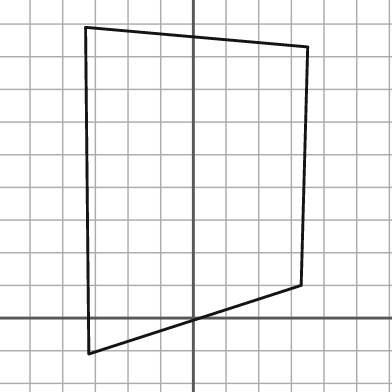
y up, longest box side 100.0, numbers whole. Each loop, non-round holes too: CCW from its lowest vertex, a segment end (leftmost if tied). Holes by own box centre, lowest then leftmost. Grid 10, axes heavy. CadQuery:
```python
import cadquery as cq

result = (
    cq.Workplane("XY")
    .moveTo(-32.0, -11.0)
    .lineTo(33.0, 10.0)
    .lineTo(35.0, 83.0)
    .lineTo(-33.0, 89.0)
    .close()
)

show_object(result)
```